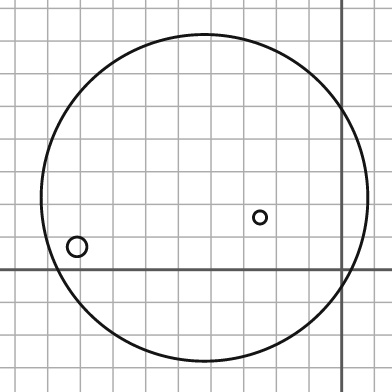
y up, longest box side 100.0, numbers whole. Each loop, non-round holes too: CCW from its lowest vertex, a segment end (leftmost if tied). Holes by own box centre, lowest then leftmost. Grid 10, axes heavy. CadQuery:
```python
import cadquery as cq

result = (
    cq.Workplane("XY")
    .moveTo(-42.0, 22.0)
    .circle(50.0)
    .moveTo(-81.0, 7.0)
    .circle(3.0)
    .moveTo(-25.0, 16.0)
    .circle(2.0)
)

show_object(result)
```